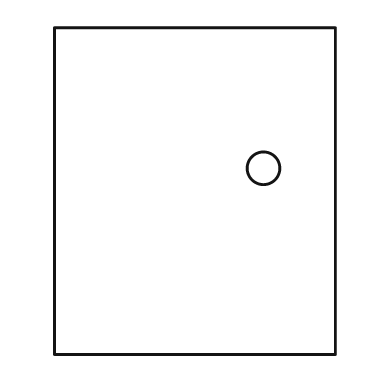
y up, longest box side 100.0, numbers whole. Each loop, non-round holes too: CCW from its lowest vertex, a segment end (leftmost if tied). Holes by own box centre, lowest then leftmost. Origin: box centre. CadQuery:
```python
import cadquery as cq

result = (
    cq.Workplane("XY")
    .moveTo(-43.0, -50.0)
    .lineTo(43.0, -50.0)
    .lineTo(43.0, 50.0)
    .lineTo(-43.0, 50.0)
    .close()
    .moveTo(21.0, 7.0)
    .circle(5.0)
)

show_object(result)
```